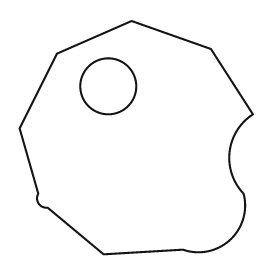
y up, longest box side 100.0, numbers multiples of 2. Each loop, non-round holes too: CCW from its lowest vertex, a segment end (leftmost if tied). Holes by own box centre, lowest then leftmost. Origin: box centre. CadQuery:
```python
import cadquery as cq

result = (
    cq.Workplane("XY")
    .moveTo(-14.0, -50.0)
    .lineTo(20.0, -48.0)
    .threePointArc((40.0, -44.0), (46.0, -24.0))
    .threePointArc((40.0, -6.0), (50.0, 10.0))
    .lineTo(32.0, 38.0)
    .lineTo(-2.0, 50.0)
    .lineTo(-34.0, 36.0)
    .lineTo(-50.0, 4.0)
    .lineTo(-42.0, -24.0)
    .threePointArc((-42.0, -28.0), (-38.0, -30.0))
    .close()
    .moveTo(-12.0, 22.0)
    .circle(12.0)
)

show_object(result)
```